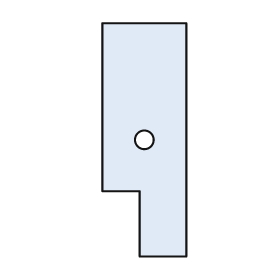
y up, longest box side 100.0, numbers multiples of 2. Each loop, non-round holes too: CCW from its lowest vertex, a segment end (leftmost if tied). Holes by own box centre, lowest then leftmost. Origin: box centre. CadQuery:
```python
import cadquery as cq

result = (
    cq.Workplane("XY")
    .moveTo(-2.0, -50.0)
    .lineTo(18.0, -50.0)
    .lineTo(18.0, 50.0)
    .lineTo(-18.0, 50.0)
    .lineTo(-18.0, -22.0)
    .lineTo(-2.0, -22.0)
    .close()
    .moveTo(0.0, 0.0)
    .circle(4.0)
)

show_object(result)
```